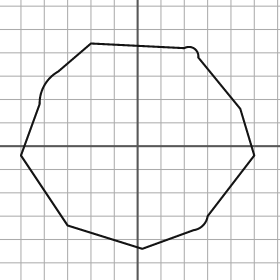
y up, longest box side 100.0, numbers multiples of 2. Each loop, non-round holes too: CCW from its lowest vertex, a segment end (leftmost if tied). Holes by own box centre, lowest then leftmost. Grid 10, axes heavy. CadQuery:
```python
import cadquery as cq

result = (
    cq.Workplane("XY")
    .moveTo(2.0, -44.0)
    .lineTo(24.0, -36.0)
    .threePointArc((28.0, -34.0), (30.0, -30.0))
    .lineTo(50.0, -4.0)
    .lineTo(44.0, 16.0)
    .lineTo(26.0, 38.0)
    .threePointArc((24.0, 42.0), (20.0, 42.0))
    .lineTo(-20.0, 44.0)
    .lineTo(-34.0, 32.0)
    .threePointArc((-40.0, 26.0), (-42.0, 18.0))
    .lineTo(-50.0, -4.0)
    .lineTo(-30.0, -34.0)
    .close()
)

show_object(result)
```